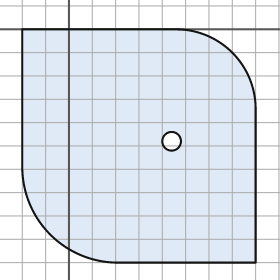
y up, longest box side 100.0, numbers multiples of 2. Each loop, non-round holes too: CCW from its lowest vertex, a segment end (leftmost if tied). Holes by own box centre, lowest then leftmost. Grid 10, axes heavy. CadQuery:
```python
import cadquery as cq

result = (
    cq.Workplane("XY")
    .moveTo(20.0, -100.0)
    .lineTo(80.0, -100.0)
    .lineTo(80.0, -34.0)
    .threePointArc((70.0, -10.0), (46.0, 0.0))
    .lineTo(-20.0, 0.0)
    .lineTo(-20.0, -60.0)
    .threePointArc((-8.0, -88.0), (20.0, -100.0))
    .close()
    .moveTo(44.0, -48.0)
    .circle(4.0)
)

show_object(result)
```